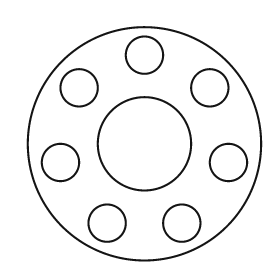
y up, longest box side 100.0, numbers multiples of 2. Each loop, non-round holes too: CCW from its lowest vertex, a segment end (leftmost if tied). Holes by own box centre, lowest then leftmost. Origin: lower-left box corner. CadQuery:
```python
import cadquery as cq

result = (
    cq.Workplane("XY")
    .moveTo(50.0, 50.0)
    .circle(50.0)
    .moveTo(34.0, 16.0)
    .circle(8.0)
    .moveTo(66.0, 16.0)
    .circle(8.0)
    .moveTo(14.0, 42.0)
    .circle(8.0)
    .moveTo(86.0, 42.0)
    .circle(8.0)
    .moveTo(50.0, 50.0)
    .circle(20.0)
    .moveTo(22.0, 74.0)
    .circle(8.0)
    .moveTo(78.0, 74.0)
    .circle(8.0)
    .moveTo(50.0, 88.0)
    .circle(8.0)
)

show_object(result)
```